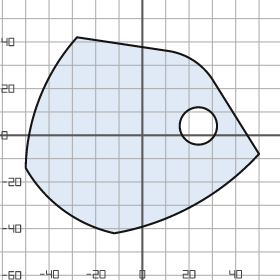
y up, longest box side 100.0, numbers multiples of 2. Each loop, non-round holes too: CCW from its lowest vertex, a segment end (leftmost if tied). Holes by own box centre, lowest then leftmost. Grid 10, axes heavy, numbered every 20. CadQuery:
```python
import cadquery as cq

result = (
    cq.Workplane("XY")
    .moveTo(-12.0, -42.0)
    .threePointArc((22.0, -30.0), (50.0, -8.0))
    .lineTo(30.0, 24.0)
    .threePointArc((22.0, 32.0), (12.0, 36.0))
    .lineTo(-28.0, 42.0)
    .threePointArc((-44.0, 16.0), (-50.0, -14.0))
    .threePointArc((-34.0, -32.0), (-12.0, -42.0))
    .close()
    .moveTo(24.0, 4.0)
    .circle(8.0)
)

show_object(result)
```